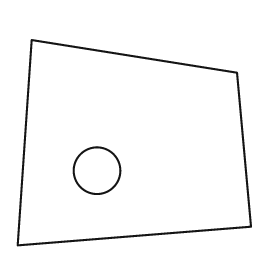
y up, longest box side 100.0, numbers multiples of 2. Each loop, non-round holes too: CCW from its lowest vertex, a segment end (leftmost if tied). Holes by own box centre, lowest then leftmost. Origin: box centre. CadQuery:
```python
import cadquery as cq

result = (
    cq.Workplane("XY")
    .moveTo(-50.0, -44.0)
    .lineTo(50.0, -36.0)
    .lineTo(44.0, 30.0)
    .lineTo(-44.0, 44.0)
    .close()
    .moveTo(-16.0, -12.0)
    .circle(10.0)
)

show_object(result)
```